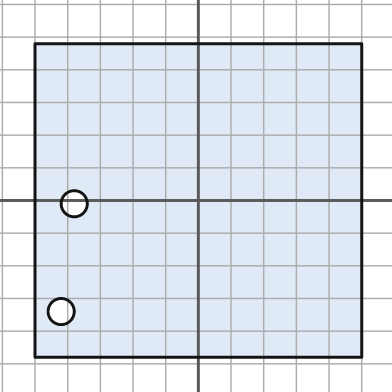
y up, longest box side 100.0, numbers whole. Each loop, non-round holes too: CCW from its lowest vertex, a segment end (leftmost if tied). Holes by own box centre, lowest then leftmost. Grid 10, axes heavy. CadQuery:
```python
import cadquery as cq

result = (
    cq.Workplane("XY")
    .moveTo(-50.0, -48.0)
    .lineTo(50.0, -48.0)
    .lineTo(50.0, 48.0)
    .lineTo(-50.0, 48.0)
    .close()
    .moveTo(-42.0, -34.0)
    .circle(4.0)
    .moveTo(-38.0, -1.0)
    .circle(4.0)
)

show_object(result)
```